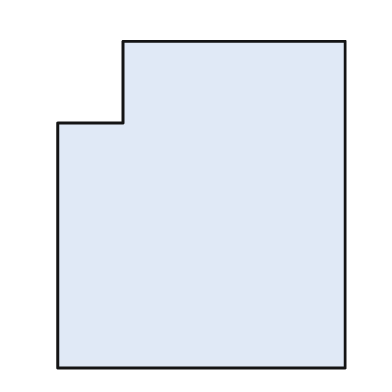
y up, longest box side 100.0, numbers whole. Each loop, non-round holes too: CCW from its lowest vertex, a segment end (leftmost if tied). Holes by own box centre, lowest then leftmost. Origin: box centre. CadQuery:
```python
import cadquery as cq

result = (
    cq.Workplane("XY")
    .moveTo(-44.0, -50.0)
    .lineTo(44.0, -50.0)
    .lineTo(44.0, 50.0)
    .lineTo(-24.0, 50.0)
    .lineTo(-24.0, 25.0)
    .lineTo(-44.0, 25.0)
    .close()
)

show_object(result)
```